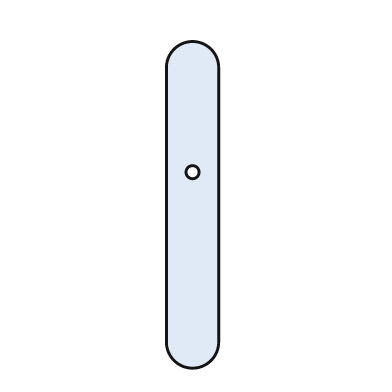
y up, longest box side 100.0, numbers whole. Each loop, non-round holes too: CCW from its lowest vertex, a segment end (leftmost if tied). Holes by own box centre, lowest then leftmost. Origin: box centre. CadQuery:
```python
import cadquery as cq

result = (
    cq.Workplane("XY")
    .moveTo(-8.0, -42.0)
    .threePointArc((0.0, -50.0), (8.0, -42.0))
    .lineTo(8.0, 42.0)
    .threePointArc((0.0, 50.0), (-8.0, 42.0))
    .close()
    .moveTo(0.0, 10.0)
    .circle(2.0)
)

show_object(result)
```